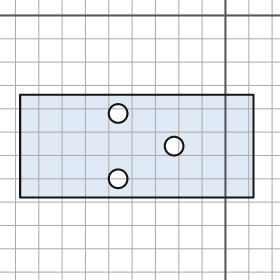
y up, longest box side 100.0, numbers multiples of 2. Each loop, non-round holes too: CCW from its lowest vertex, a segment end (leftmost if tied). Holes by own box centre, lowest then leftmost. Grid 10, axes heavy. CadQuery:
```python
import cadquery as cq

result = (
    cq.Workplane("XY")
    .moveTo(-88.0, -78.0)
    .lineTo(12.0, -78.0)
    .lineTo(12.0, -34.0)
    .lineTo(-88.0, -34.0)
    .close()
    .moveTo(-46.0, -70.0)
    .circle(4.0)
    .moveTo(-22.0, -56.0)
    .circle(4.0)
    .moveTo(-46.0, -42.0)
    .circle(4.0)
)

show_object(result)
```